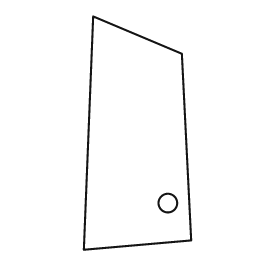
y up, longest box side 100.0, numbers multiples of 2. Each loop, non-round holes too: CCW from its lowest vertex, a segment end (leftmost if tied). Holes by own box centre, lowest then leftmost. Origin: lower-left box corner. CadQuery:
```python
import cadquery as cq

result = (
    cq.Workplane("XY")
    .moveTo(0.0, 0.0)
    .lineTo(46.0, 4.0)
    .lineTo(42.0, 84.0)
    .lineTo(4.0, 100.0)
    .close()
    .moveTo(36.0, 20.0)
    .circle(4.0)
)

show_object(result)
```